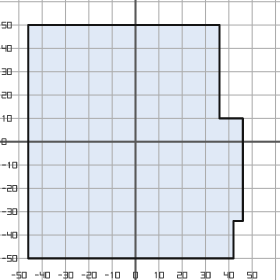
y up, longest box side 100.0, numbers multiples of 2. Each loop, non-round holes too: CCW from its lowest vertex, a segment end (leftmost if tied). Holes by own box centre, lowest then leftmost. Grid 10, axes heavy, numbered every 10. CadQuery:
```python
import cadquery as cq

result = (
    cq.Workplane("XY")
    .moveTo(-46.0, -50.0)
    .lineTo(42.0, -50.0)
    .lineTo(42.0, -34.0)
    .lineTo(46.0, -34.0)
    .lineTo(46.0, 10.0)
    .lineTo(36.0, 10.0)
    .lineTo(36.0, 50.0)
    .lineTo(-46.0, 50.0)
    .close()
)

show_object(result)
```